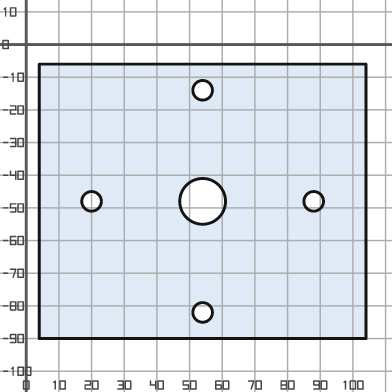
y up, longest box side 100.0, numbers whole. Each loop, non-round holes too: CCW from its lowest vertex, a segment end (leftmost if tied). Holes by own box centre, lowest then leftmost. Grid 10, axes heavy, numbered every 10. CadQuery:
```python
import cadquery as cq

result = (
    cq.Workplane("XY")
    .moveTo(4.0, -90.0)
    .lineTo(104.0, -90.0)
    .lineTo(104.0, -6.0)
    .lineTo(4.0, -6.0)
    .close()
    .moveTo(54.0, -82.0)
    .circle(3.0)
    .moveTo(20.0, -48.0)
    .circle(3.0)
    .moveTo(54.0, -48.0)
    .circle(7.0)
    .moveTo(88.0, -48.0)
    .circle(3.0)
    .moveTo(54.0, -14.0)
    .circle(3.0)
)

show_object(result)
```